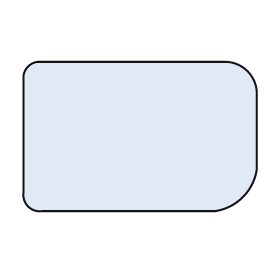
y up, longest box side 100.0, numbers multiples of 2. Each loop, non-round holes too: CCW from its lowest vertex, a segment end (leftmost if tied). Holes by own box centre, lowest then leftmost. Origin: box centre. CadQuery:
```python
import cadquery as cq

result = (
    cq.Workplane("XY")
    .moveTo(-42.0, -32.0)
    .lineTo(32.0, -32.0)
    .threePointArc((44.0, -26.0), (50.0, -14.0))
    .lineTo(50.0, 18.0)
    .threePointArc((46.0, 28.0), (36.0, 32.0))
    .lineTo(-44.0, 32.0)
    .threePointArc((-48.0, 30.0), (-50.0, 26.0))
    .lineTo(-50.0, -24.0)
    .threePointArc((-48.0, -30.0), (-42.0, -32.0))
    .close()
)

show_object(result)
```